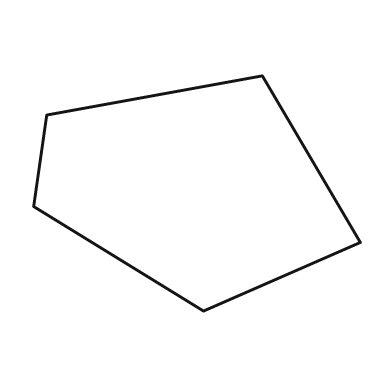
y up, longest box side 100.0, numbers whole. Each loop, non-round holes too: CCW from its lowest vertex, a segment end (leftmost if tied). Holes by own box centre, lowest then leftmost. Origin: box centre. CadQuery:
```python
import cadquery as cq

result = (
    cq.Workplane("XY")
    .moveTo(2.0, -36.0)
    .lineTo(50.0, -15.0)
    .lineTo(20.0, 36.0)
    .lineTo(-46.0, 24.0)
    .lineTo(-50.0, -4.0)
    .close()
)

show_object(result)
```